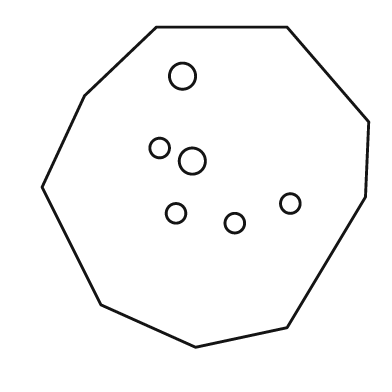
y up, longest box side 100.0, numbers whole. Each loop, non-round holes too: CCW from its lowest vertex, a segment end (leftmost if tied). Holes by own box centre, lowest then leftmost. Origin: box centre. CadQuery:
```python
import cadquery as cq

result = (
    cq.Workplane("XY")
    .moveTo(-3.0, -49.0)
    .lineTo(25.0, -43.0)
    .lineTo(49.0, -3.0)
    .lineTo(50.0, 20.0)
    .lineTo(25.0, 49.0)
    .lineTo(-15.0, 49.0)
    .lineTo(-37.0, 28.0)
    .lineTo(-50.0, 0.0)
    .lineTo(-32.0, -36.0)
    .close()
    .moveTo(9.0, -11.0)
    .circle(3.0)
    .moveTo(-9.0, -8.0)
    .circle(3.0)
    .moveTo(26.0, -5.0)
    .circle(3.0)
    .moveTo(-4.0, 8.0)
    .circle(4.0)
    .moveTo(-14.0, 12.0)
    .circle(3.0)
    .moveTo(-7.0, 34.0)
    .circle(4.0)
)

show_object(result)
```